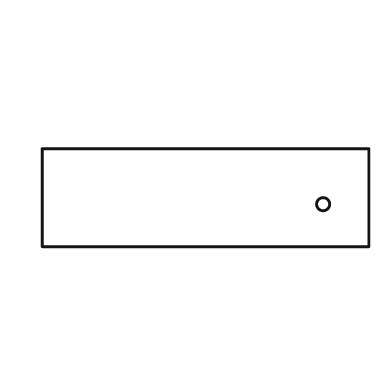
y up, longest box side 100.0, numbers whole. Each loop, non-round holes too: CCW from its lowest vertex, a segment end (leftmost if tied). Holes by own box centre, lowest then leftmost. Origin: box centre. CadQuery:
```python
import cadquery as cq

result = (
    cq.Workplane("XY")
    .moveTo(-50.0, -15.0)
    .lineTo(50.0, -15.0)
    .lineTo(50.0, 15.0)
    .lineTo(-50.0, 15.0)
    .close()
    .moveTo(36.0, -2.0)
    .circle(2.0)
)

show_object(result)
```